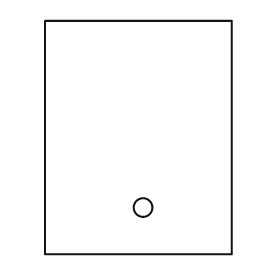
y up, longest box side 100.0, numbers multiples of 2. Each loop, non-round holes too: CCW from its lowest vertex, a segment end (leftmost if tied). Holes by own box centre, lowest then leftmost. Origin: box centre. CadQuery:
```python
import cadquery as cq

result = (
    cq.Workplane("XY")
    .moveTo(-40.0, -50.0)
    .lineTo(40.0, -50.0)
    .lineTo(40.0, 50.0)
    .lineTo(-40.0, 50.0)
    .close()
    .moveTo(2.0, -30.0)
    .circle(4.0)
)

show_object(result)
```